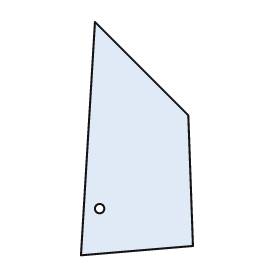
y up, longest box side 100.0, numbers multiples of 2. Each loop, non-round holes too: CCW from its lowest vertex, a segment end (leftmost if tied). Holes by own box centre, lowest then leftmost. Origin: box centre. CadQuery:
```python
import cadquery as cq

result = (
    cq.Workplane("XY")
    .moveTo(-24.0, -50.0)
    .lineTo(24.0, -46.0)
    .lineTo(22.0, 10.0)
    .lineTo(-18.0, 50.0)
    .close()
    .moveTo(-16.0, -30.0)
    .circle(2.0)
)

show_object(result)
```